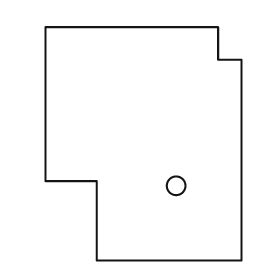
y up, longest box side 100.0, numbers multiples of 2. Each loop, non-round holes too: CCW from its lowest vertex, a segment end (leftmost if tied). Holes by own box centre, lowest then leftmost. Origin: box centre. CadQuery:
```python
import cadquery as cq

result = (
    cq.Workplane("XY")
    .moveTo(-20.0, -50.0)
    .lineTo(42.0, -50.0)
    .lineTo(42.0, 36.0)
    .lineTo(32.0, 36.0)
    .lineTo(32.0, 50.0)
    .lineTo(-42.0, 50.0)
    .lineTo(-42.0, -16.0)
    .lineTo(-20.0, -16.0)
    .close()
    .moveTo(14.0, -18.0)
    .circle(4.0)
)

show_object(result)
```